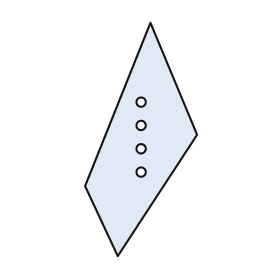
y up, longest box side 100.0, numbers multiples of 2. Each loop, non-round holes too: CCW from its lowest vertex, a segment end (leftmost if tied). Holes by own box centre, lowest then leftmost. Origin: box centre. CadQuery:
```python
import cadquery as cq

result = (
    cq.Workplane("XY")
    .moveTo(-10.0, -50.0)
    .lineTo(24.0, 2.0)
    .lineTo(4.0, 50.0)
    .lineTo(-24.0, -20.0)
    .close()
    .moveTo(0.0, -14.0)
    .circle(2.0)
    .moveTo(0.0, -4.0)
    .circle(2.0)
    .moveTo(0.0, 6.0)
    .circle(2.0)
    .moveTo(0.0, 16.0)
    .circle(2.0)
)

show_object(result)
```